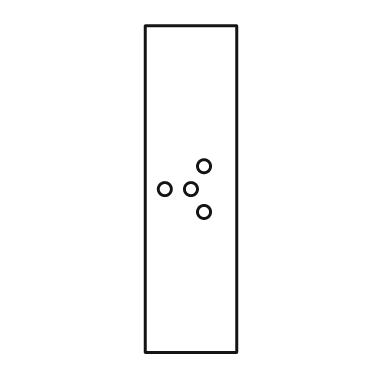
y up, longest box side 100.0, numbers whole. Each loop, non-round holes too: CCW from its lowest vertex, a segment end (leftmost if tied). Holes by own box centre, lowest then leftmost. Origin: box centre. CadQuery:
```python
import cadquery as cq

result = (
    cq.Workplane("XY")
    .moveTo(-14.0, -50.0)
    .lineTo(14.0, -50.0)
    .lineTo(14.0, 50.0)
    .lineTo(-14.0, 50.0)
    .close()
    .moveTo(4.0, -7.0)
    .circle(2.0)
    .moveTo(-8.0, 0.0)
    .circle(2.0)
    .moveTo(0.0, 0.0)
    .circle(2.0)
    .moveTo(4.0, 7.0)
    .circle(2.0)
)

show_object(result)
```